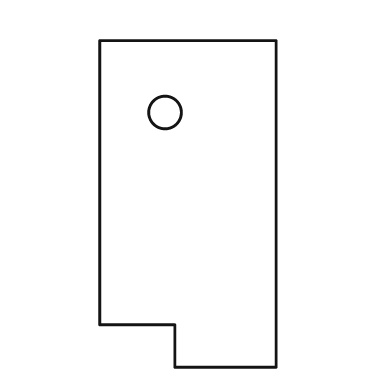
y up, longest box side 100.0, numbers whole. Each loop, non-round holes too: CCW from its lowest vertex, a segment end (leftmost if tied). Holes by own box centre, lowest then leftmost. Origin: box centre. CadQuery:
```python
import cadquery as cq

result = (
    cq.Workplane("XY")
    .moveTo(-4.0, -50.0)
    .lineTo(27.0, -50.0)
    .lineTo(27.0, 50.0)
    .lineTo(-27.0, 50.0)
    .lineTo(-27.0, -37.0)
    .lineTo(-4.0, -37.0)
    .close()
    .moveTo(-7.0, 28.0)
    .circle(5.0)
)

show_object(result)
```